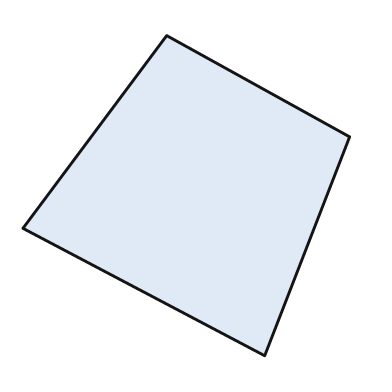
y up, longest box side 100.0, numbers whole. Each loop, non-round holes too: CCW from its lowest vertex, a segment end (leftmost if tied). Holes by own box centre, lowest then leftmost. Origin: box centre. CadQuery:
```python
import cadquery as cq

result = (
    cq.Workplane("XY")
    .moveTo(24.0, -49.0)
    .lineTo(50.0, 18.0)
    .lineTo(-6.0, 49.0)
    .lineTo(-50.0, -10.0)
    .close()
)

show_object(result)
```